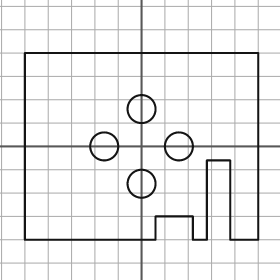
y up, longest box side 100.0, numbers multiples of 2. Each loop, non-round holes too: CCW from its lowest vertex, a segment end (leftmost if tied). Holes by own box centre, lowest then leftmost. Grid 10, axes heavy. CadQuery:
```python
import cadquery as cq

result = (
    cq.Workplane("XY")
    .moveTo(-50.0, -40.0)
    .lineTo(6.0, -40.0)
    .lineTo(6.0, -30.0)
    .lineTo(22.0, -30.0)
    .lineTo(22.0, -40.0)
    .lineTo(28.0, -40.0)
    .lineTo(28.0, -6.0)
    .lineTo(38.0, -6.0)
    .lineTo(38.0, -40.0)
    .lineTo(50.0, -40.0)
    .lineTo(50.0, 40.0)
    .lineTo(-50.0, 40.0)
    .close()
    .moveTo(0.0, -16.0)
    .circle(6.0)
    .moveTo(-16.0, 0.0)
    .circle(6.0)
    .moveTo(16.0, 0.0)
    .circle(6.0)
    .moveTo(0.0, 16.0)
    .circle(6.0)
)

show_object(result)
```